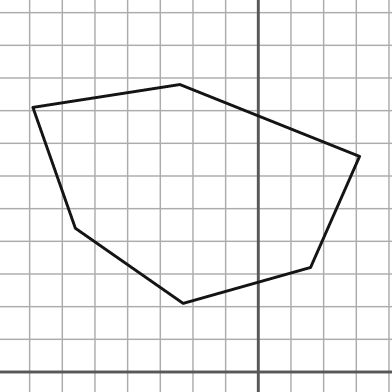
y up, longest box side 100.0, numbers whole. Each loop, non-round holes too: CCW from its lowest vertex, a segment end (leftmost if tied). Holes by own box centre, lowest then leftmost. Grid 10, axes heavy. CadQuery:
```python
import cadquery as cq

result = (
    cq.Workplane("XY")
    .moveTo(-23.0, 21.0)
    .lineTo(16.0, 32.0)
    .lineTo(31.0, 66.0)
    .lineTo(-24.0, 88.0)
    .lineTo(-69.0, 81.0)
    .lineTo(-56.0, 44.0)
    .close()
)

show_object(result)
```